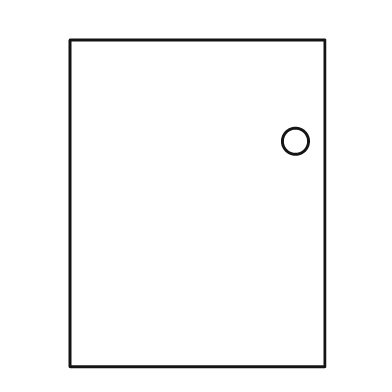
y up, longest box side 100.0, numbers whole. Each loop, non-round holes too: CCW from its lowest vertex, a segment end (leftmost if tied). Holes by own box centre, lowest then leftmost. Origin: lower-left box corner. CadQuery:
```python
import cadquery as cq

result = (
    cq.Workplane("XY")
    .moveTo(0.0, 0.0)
    .lineTo(78.0, 0.0)
    .lineTo(78.0, 100.0)
    .lineTo(0.0, 100.0)
    .close()
    .moveTo(69.0, 69.0)
    .circle(4.0)
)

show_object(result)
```